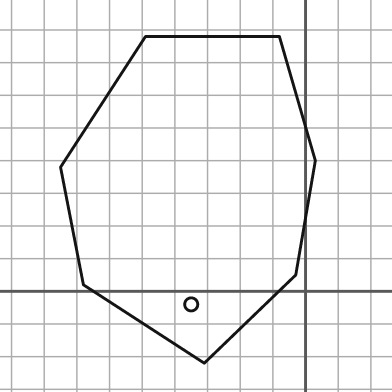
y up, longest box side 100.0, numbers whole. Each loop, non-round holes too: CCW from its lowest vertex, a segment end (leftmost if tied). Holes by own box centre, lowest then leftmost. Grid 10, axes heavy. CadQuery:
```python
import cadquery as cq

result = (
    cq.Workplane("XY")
    .moveTo(-31.0, -22.0)
    .lineTo(-3.0, 5.0)
    .lineTo(3.0, 40.0)
    .lineTo(-8.0, 78.0)
    .lineTo(-49.0, 78.0)
    .lineTo(-75.0, 38.0)
    .lineTo(-68.0, 2.0)
    .close()
    .moveTo(-35.0, -4.0)
    .circle(2.0)
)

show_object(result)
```